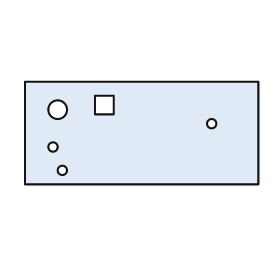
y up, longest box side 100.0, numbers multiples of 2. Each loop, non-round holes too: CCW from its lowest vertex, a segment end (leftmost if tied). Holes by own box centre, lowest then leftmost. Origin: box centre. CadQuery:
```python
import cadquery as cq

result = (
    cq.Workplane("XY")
    .moveTo(-50.0, -22.0)
    .lineTo(50.0, -22.0)
    .lineTo(50.0, 22.0)
    .lineTo(-50.0, 22.0)
    .close()
    .moveTo(-34.0, -16.0)
    .circle(2.0)
    .moveTo(-38.0, -6.0)
    .circle(2.0)
    .moveTo(30.0, 4.0)
    .circle(2.0)
    .moveTo(-36.0, 10.0)
    .circle(4.0)
    .moveTo(-20.0, 8.0)
    .lineTo(-12.0, 8.0)
    .lineTo(-12.0, 16.0)
    .lineTo(-20.0, 16.0)
    .close()
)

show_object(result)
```